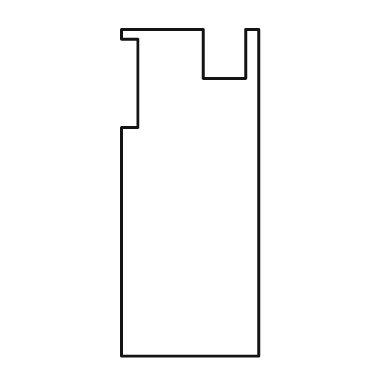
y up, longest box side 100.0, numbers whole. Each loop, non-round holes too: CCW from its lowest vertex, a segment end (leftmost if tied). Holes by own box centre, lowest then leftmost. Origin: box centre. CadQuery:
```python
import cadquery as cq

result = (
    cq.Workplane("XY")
    .moveTo(-21.0, -50.0)
    .lineTo(21.0, -50.0)
    .lineTo(21.0, 50.0)
    .lineTo(17.0, 50.0)
    .lineTo(17.0, 35.0)
    .lineTo(4.0, 35.0)
    .lineTo(4.0, 50.0)
    .lineTo(-21.0, 50.0)
    .lineTo(-21.0, 47.0)
    .lineTo(-16.0, 47.0)
    .lineTo(-16.0, 20.0)
    .lineTo(-21.0, 20.0)
    .close()
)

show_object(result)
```